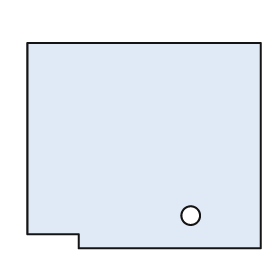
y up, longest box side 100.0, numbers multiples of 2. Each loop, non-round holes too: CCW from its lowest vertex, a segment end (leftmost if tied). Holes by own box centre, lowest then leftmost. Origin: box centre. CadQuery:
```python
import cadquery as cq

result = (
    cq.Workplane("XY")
    .moveTo(-28.0, -44.0)
    .lineTo(50.0, -44.0)
    .lineTo(50.0, 44.0)
    .lineTo(-50.0, 44.0)
    .lineTo(-50.0, -38.0)
    .lineTo(-28.0, -38.0)
    .close()
    .moveTo(20.0, -30.0)
    .circle(4.0)
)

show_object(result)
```